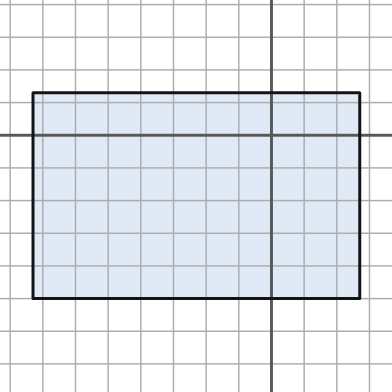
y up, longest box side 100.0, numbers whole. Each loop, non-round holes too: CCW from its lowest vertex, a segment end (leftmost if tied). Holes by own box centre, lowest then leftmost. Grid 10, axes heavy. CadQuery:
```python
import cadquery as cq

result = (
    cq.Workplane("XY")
    .moveTo(-73.0, -50.0)
    .lineTo(27.0, -50.0)
    .lineTo(27.0, 13.0)
    .lineTo(-73.0, 13.0)
    .close()
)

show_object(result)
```